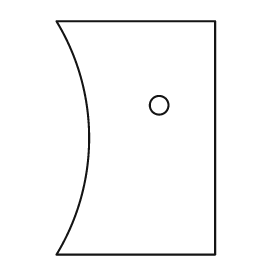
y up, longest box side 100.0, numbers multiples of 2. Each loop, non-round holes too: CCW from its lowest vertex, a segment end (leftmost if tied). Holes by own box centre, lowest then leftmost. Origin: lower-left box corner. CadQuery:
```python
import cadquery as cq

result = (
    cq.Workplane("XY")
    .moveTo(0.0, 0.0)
    .lineTo(68.0, 0.0)
    .lineTo(68.0, 100.0)
    .lineTo(0.0, 100.0)
    .threePointArc((14.0, 50.0), (0.0, 0.0))
    .close()
    .moveTo(44.0, 64.0)
    .circle(4.0)
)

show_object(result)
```